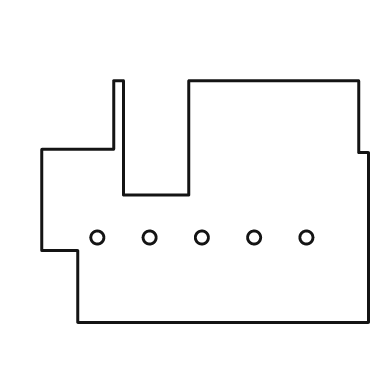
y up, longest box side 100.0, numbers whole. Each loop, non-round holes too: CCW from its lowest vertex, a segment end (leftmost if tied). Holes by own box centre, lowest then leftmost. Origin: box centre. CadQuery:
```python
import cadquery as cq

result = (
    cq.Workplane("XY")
    .moveTo(-39.0, -37.0)
    .lineTo(50.0, -37.0)
    .lineTo(50.0, 15.0)
    .lineTo(47.0, 15.0)
    .lineTo(47.0, 37.0)
    .lineTo(-5.0, 37.0)
    .lineTo(-5.0, 2.0)
    .lineTo(-25.0, 2.0)
    .lineTo(-25.0, 37.0)
    .lineTo(-28.0, 37.0)
    .lineTo(-28.0, 16.0)
    .lineTo(-50.0, 16.0)
    .lineTo(-50.0, -15.0)
    .lineTo(-39.0, -15.0)
    .close()
    .moveTo(-33.0, -11.0)
    .circle(2.0)
    .moveTo(-17.0, -11.0)
    .circle(2.0)
    .moveTo(-1.0, -11.0)
    .circle(2.0)
    .moveTo(15.0, -11.0)
    .circle(2.0)
    .moveTo(31.0, -11.0)
    .circle(2.0)
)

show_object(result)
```